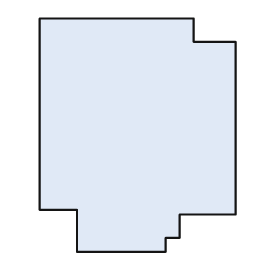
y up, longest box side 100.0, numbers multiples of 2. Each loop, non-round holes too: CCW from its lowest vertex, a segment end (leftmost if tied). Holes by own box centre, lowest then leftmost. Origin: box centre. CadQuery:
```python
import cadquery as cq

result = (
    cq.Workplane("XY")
    .moveTo(-26.0, -50.0)
    .lineTo(12.0, -50.0)
    .lineTo(12.0, -44.0)
    .lineTo(18.0, -44.0)
    .lineTo(18.0, -34.0)
    .lineTo(42.0, -34.0)
    .lineTo(42.0, 40.0)
    .lineTo(24.0, 40.0)
    .lineTo(24.0, 50.0)
    .lineTo(-42.0, 50.0)
    .lineTo(-42.0, -32.0)
    .lineTo(-26.0, -32.0)
    .close()
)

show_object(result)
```